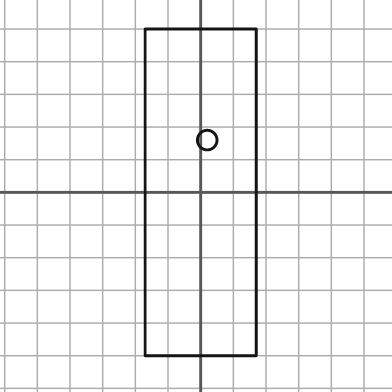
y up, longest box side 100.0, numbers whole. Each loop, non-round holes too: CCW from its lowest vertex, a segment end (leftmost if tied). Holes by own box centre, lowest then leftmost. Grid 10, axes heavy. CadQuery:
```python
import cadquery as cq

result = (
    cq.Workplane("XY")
    .moveTo(-17.0, -50.0)
    .lineTo(17.0, -50.0)
    .lineTo(17.0, 50.0)
    .lineTo(-17.0, 50.0)
    .close()
    .moveTo(2.0, 16.0)
    .circle(3.0)
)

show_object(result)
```